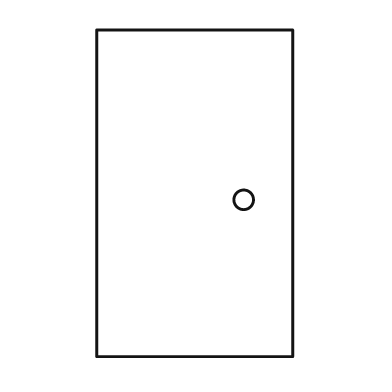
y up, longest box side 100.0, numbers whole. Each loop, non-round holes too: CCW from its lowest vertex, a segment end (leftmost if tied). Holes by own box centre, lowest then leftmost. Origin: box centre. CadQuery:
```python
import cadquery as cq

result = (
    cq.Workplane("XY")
    .moveTo(-30.0, -50.0)
    .lineTo(30.0, -50.0)
    .lineTo(30.0, 50.0)
    .lineTo(-30.0, 50.0)
    .close()
    .moveTo(15.0, -2.0)
    .circle(3.0)
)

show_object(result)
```